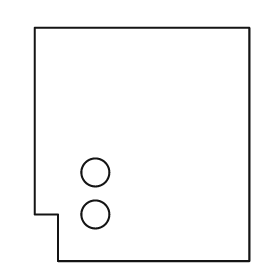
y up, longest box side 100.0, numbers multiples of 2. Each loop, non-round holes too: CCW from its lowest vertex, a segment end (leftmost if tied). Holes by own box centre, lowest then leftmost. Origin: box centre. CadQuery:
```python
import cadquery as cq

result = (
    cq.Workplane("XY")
    .moveTo(-36.0, -50.0)
    .lineTo(46.0, -50.0)
    .lineTo(46.0, 50.0)
    .lineTo(-46.0, 50.0)
    .lineTo(-46.0, -30.0)
    .lineTo(-36.0, -30.0)
    .close()
    .moveTo(-20.0, -30.0)
    .circle(6.0)
    .moveTo(-20.0, -12.0)
    .circle(6.0)
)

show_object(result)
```